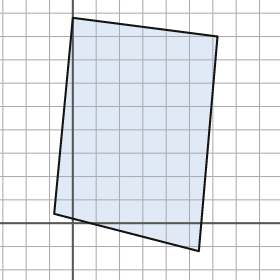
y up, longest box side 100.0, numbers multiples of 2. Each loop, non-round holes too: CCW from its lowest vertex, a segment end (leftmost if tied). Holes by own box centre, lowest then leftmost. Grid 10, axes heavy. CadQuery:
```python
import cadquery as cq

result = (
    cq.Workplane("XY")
    .moveTo(54.0, -12.0)
    .lineTo(62.0, 80.0)
    .lineTo(0.0, 88.0)
    .lineTo(-8.0, 4.0)
    .close()
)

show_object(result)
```